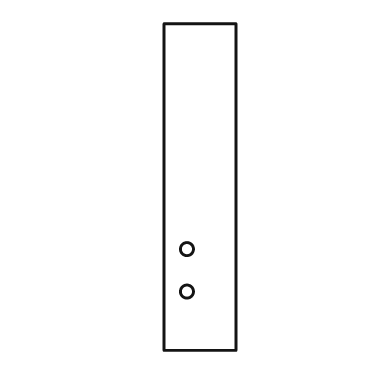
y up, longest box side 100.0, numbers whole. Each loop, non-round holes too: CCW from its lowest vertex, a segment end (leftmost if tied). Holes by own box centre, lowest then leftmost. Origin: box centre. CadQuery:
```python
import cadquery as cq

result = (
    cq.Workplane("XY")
    .moveTo(-11.0, -50.0)
    .lineTo(11.0, -50.0)
    .lineTo(11.0, 50.0)
    .lineTo(-11.0, 50.0)
    .close()
    .moveTo(-4.0, -32.0)
    .circle(2.0)
    .moveTo(-4.0, -19.0)
    .circle(2.0)
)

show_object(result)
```